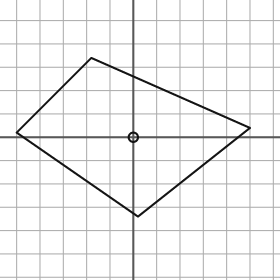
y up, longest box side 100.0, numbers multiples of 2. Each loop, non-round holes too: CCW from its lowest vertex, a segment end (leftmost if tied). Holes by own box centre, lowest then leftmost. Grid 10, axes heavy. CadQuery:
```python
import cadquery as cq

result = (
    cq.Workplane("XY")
    .moveTo(2.0, -34.0)
    .lineTo(50.0, 4.0)
    .lineTo(-18.0, 34.0)
    .lineTo(-50.0, 2.0)
    .close()
    .moveTo(0.0, 0.0)
    .circle(2.0)
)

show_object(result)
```